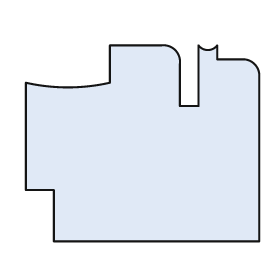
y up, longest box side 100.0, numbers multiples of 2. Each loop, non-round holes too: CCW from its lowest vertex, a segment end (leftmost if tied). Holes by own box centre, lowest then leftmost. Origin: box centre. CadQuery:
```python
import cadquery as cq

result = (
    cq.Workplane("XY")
    .moveTo(-38.0, -42.0)
    .lineTo(50.0, -42.0)
    .lineTo(50.0, 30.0)
    .threePointArc((48.0, 34.0), (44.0, 36.0))
    .lineTo(32.0, 36.0)
    .lineTo(32.0, 42.0)
    .threePointArc((28.0, 40.0), (24.0, 42.0))
    .lineTo(24.0, 16.0)
    .lineTo(16.0, 16.0)
    .lineTo(16.0, 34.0)
    .threePointArc((14.0, 40.0), (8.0, 42.0))
    .lineTo(-14.0, 42.0)
    .lineTo(-14.0, 26.0)
    .threePointArc((-32.0, 24.0), (-50.0, 26.0))
    .lineTo(-50.0, -20.0)
    .lineTo(-38.0, -20.0)
    .close()
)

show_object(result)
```